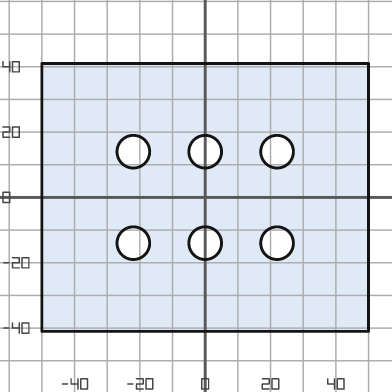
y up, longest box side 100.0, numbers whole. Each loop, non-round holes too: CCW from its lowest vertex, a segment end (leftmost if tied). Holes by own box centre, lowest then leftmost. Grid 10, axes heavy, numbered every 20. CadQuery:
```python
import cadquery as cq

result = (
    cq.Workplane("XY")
    .moveTo(-50.0, -41.0)
    .lineTo(50.0, -41.0)
    .lineTo(50.0, 41.0)
    .lineTo(-50.0, 41.0)
    .close()
    .moveTo(-22.0, -14.0)
    .circle(5.0)
    .moveTo(0.0, -14.0)
    .circle(5.0)
    .moveTo(22.0, -14.0)
    .circle(5.0)
    .moveTo(-22.0, 14.0)
    .circle(5.0)
    .moveTo(0.0, 14.0)
    .circle(5.0)
    .moveTo(22.0, 14.0)
    .circle(5.0)
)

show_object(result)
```